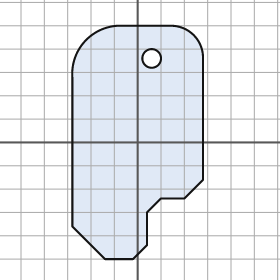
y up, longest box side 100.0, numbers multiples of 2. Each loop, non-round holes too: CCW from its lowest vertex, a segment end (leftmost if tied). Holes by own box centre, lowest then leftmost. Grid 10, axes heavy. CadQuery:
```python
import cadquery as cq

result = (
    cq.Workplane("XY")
    .moveTo(-14.0, -50.0)
    .lineTo(-2.0, -50.0)
    .lineTo(4.0, -44.0)
    .lineTo(4.0, -30.0)
    .lineTo(10.0, -24.0)
    .lineTo(20.0, -24.0)
    .lineTo(28.0, -16.0)
    .lineTo(28.0, 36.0)
    .threePointArc((24.0, 46.0), (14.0, 50.0))
    .lineTo(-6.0, 50.0)
    .threePointArc((-22.0, 44.0), (-28.0, 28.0))
    .lineTo(-28.0, -36.0)
    .close()
    .moveTo(6.0, 36.0)
    .circle(4.0)
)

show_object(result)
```